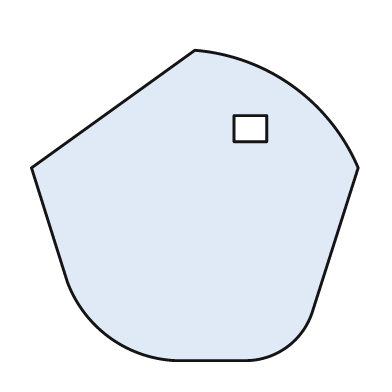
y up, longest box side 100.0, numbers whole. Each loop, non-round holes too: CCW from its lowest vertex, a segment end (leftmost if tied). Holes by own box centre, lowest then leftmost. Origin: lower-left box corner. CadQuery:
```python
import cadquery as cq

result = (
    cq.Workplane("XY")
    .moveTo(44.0, 0.0)
    .lineTo(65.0, 0.0)
    .threePointArc((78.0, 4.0), (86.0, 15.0))
    .lineTo(100.0, 59.0)
    .threePointArc((80.0, 84.0), (50.0, 95.0))
    .lineTo(0.0, 59.0)
    .lineTo(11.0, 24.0)
    .threePointArc((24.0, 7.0), (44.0, 0.0))
    .close()
    .moveTo(62.0, 67.0)
    .lineTo(72.0, 67.0)
    .lineTo(72.0, 75.0)
    .lineTo(62.0, 75.0)
    .close()
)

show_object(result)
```